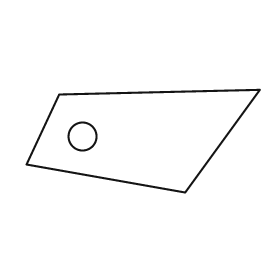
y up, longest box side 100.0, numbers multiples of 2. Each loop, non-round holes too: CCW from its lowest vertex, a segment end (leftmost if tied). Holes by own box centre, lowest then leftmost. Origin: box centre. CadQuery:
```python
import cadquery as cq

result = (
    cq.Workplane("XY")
    .moveTo(18.0, -22.0)
    .lineTo(50.0, 22.0)
    .lineTo(-36.0, 20.0)
    .lineTo(-50.0, -10.0)
    .close()
    .moveTo(-26.0, 2.0)
    .circle(6.0)
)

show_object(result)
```